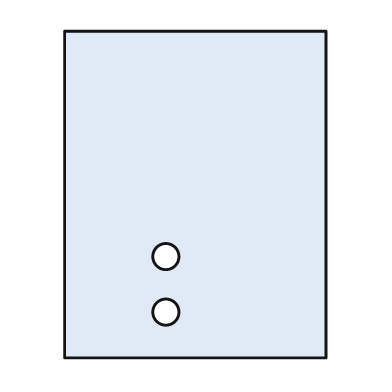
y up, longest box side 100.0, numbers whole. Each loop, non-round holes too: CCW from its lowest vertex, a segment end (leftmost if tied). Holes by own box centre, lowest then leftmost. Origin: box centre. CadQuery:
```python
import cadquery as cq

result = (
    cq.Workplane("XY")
    .moveTo(-40.0, -50.0)
    .lineTo(40.0, -50.0)
    .lineTo(40.0, 50.0)
    .lineTo(-40.0, 50.0)
    .close()
    .moveTo(-9.0, -36.0)
    .circle(4.0)
    .moveTo(-9.0, -19.0)
    .circle(4.0)
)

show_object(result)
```